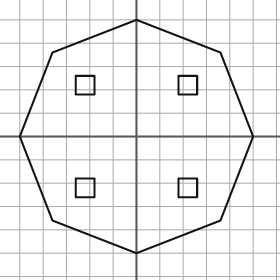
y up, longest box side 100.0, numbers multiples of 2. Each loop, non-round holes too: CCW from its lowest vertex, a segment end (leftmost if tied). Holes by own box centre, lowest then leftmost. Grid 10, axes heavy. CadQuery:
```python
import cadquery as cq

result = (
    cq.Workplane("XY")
    .moveTo(0.0, -50.0)
    .lineTo(36.0, -36.0)
    .lineTo(50.0, 0.0)
    .lineTo(36.0, 36.0)
    .lineTo(0.0, 50.0)
    .lineTo(-36.0, 36.0)
    .lineTo(-50.0, 0.0)
    .lineTo(-36.0, -36.0)
    .close()
    .moveTo(-26.0, -26.0)
    .lineTo(-18.0, -26.0)
    .lineTo(-18.0, -18.0)
    .lineTo(-26.0, -18.0)
    .close()
    .moveTo(18.0, -26.0)
    .lineTo(26.0, -26.0)
    .lineTo(26.0, -18.0)
    .lineTo(18.0, -18.0)
    .close()
    .moveTo(-26.0, 18.0)
    .lineTo(-18.0, 18.0)
    .lineTo(-18.0, 26.0)
    .lineTo(-26.0, 26.0)
    .close()
    .moveTo(18.0, 18.0)
    .lineTo(26.0, 18.0)
    .lineTo(26.0, 26.0)
    .lineTo(18.0, 26.0)
    .close()
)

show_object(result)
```